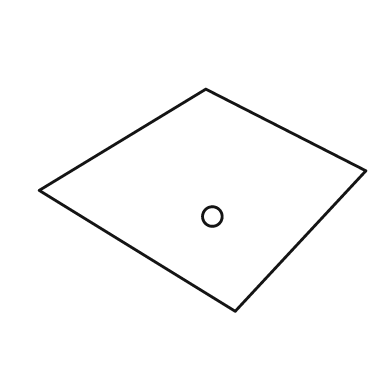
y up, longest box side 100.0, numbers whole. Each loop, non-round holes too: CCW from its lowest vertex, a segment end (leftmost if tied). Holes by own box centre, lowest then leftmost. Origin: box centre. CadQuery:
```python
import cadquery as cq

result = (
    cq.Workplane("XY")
    .moveTo(10.0, -34.0)
    .lineTo(50.0, 9.0)
    .lineTo(1.0, 34.0)
    .lineTo(-50.0, 3.0)
    .close()
    .moveTo(3.0, -5.0)
    .circle(3.0)
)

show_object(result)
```